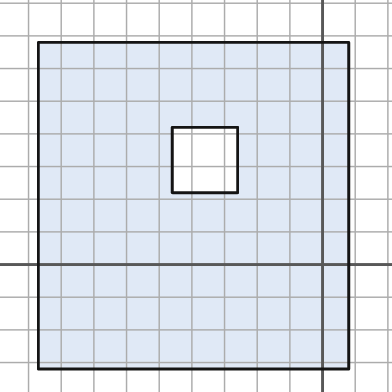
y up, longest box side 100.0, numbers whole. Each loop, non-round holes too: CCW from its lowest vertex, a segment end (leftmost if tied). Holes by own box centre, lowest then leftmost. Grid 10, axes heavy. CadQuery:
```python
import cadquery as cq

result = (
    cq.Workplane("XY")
    .moveTo(-87.0, -32.0)
    .lineTo(8.0, -32.0)
    .lineTo(8.0, 68.0)
    .lineTo(-87.0, 68.0)
    .close()
    .moveTo(-46.0, 22.0)
    .lineTo(-26.0, 22.0)
    .lineTo(-26.0, 42.0)
    .lineTo(-46.0, 42.0)
    .close()
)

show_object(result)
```